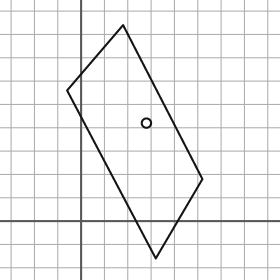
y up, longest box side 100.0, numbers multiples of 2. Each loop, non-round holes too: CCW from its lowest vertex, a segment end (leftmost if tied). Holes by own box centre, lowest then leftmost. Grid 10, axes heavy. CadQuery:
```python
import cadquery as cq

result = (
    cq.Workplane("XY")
    .moveTo(32.0, -16.0)
    .lineTo(52.0, 18.0)
    .lineTo(18.0, 84.0)
    .lineTo(-6.0, 56.0)
    .close()
    .moveTo(28.0, 42.0)
    .circle(2.0)
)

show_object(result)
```